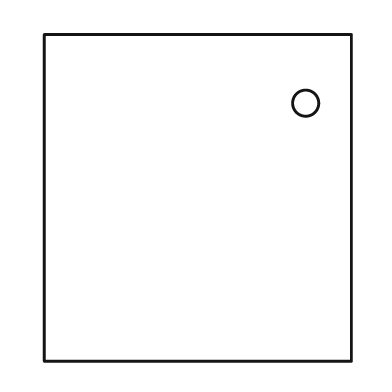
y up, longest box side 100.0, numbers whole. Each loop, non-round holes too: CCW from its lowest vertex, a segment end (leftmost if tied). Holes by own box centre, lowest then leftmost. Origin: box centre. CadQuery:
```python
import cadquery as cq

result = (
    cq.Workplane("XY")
    .moveTo(-47.0, -50.0)
    .lineTo(47.0, -50.0)
    .lineTo(47.0, 50.0)
    .lineTo(-47.0, 50.0)
    .close()
    .moveTo(33.0, 29.0)
    .circle(4.0)
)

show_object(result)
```